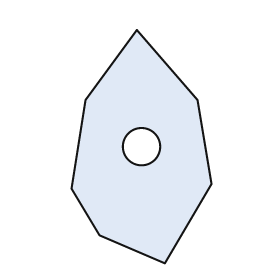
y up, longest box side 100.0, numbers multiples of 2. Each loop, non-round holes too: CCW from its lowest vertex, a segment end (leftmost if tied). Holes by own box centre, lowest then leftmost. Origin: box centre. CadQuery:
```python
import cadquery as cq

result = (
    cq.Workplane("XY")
    .moveTo(10.0, -50.0)
    .lineTo(30.0, -16.0)
    .lineTo(24.0, 20.0)
    .lineTo(-2.0, 50.0)
    .lineTo(-24.0, 20.0)
    .lineTo(-30.0, -18.0)
    .lineTo(-18.0, -38.0)
    .close()
    .moveTo(0.0, 0.0)
    .circle(8.0)
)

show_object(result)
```